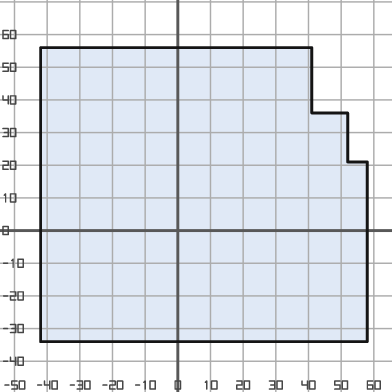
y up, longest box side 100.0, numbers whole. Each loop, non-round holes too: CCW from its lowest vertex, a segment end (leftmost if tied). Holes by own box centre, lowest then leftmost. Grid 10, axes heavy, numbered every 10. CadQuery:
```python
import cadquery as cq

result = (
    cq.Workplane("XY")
    .moveTo(-42.0, -34.0)
    .lineTo(58.0, -34.0)
    .lineTo(58.0, 21.0)
    .lineTo(52.0, 21.0)
    .lineTo(52.0, 36.0)
    .lineTo(41.0, 36.0)
    .lineTo(41.0, 56.0)
    .lineTo(-42.0, 56.0)
    .close()
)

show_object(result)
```